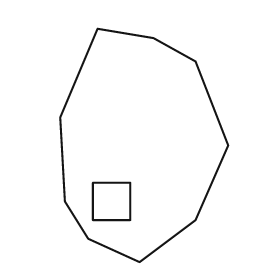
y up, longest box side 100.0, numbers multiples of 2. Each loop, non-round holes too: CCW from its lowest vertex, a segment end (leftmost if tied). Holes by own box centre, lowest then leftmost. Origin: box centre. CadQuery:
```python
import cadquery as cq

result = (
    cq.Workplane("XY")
    .moveTo(-2.0, -50.0)
    .lineTo(22.0, -32.0)
    .lineTo(36.0, 0.0)
    .lineTo(22.0, 36.0)
    .lineTo(4.0, 46.0)
    .lineTo(-20.0, 50.0)
    .lineTo(-36.0, 12.0)
    .lineTo(-34.0, -24.0)
    .lineTo(-24.0, -40.0)
    .close()
    .moveTo(-22.0, -32.0)
    .lineTo(-6.0, -32.0)
    .lineTo(-6.0, -16.0)
    .lineTo(-22.0, -16.0)
    .close()
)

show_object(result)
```